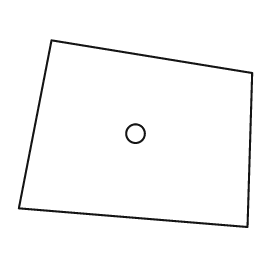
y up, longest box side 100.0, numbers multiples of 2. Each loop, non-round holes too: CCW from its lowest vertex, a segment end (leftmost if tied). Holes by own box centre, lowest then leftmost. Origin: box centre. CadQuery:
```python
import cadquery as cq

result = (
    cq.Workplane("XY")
    .moveTo(48.0, -40.0)
    .lineTo(50.0, 26.0)
    .lineTo(-36.0, 40.0)
    .lineTo(-50.0, -32.0)
    .close()
    .moveTo(0.0, 0.0)
    .circle(4.0)
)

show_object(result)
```